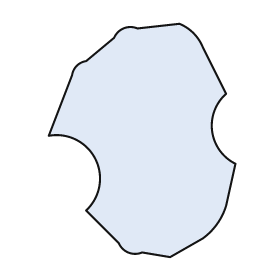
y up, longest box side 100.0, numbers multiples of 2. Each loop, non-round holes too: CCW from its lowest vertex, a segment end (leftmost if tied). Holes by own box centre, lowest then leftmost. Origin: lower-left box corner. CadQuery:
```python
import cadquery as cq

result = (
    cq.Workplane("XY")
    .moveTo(52.0, 0.0)
    .lineTo(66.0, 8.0)
    .threePointArc((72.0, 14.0), (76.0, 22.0))
    .lineTo(80.0, 40.0)
    .threePointArc((70.0, 54.0), (76.0, 70.0))
    .lineTo(66.0, 90.0)
    .threePointArc((62.0, 96.0), (56.0, 100.0))
    .lineTo(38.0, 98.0)
    .threePointArc((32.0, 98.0), (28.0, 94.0))
    .lineTo(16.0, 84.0)
    .threePointArc((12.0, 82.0), (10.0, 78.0))
    .lineTo(0.0, 52.0)
    .threePointArc((20.0, 42.0), (16.0, 20.0))
    .lineTo(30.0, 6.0)
    .threePointArc((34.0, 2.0), (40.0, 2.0))
    .close()
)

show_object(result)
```